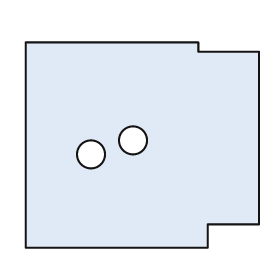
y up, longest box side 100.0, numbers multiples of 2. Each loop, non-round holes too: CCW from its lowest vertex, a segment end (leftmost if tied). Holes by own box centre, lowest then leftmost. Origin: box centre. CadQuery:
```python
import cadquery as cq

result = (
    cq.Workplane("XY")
    .moveTo(-50.0, -44.0)
    .lineTo(28.0, -44.0)
    .lineTo(28.0, -34.0)
    .lineTo(50.0, -34.0)
    .lineTo(50.0, 40.0)
    .lineTo(24.0, 40.0)
    .lineTo(24.0, 44.0)
    .lineTo(-50.0, 44.0)
    .close()
    .moveTo(-22.0, -4.0)
    .circle(6.0)
    .moveTo(-4.0, 2.0)
    .circle(6.0)
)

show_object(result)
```